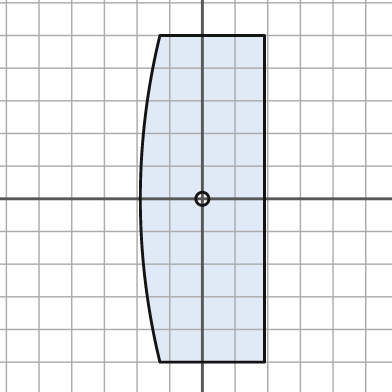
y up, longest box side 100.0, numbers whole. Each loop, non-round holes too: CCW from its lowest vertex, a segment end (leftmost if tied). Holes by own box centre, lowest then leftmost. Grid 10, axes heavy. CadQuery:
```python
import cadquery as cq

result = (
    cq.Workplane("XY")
    .moveTo(-13.0, -50.0)
    .lineTo(19.0, -50.0)
    .lineTo(19.0, 50.0)
    .lineTo(-13.0, 50.0)
    .threePointArc((-19.0, 0.0), (-13.0, -50.0))
    .close()
    .moveTo(0.0, 0.0)
    .circle(2.0)
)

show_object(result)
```